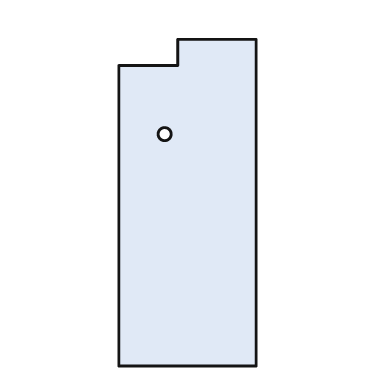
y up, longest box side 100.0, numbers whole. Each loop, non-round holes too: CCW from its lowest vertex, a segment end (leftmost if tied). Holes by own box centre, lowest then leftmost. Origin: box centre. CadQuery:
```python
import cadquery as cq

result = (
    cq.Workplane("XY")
    .moveTo(-21.0, -50.0)
    .lineTo(21.0, -50.0)
    .lineTo(21.0, 50.0)
    .lineTo(-3.0, 50.0)
    .lineTo(-3.0, 42.0)
    .lineTo(-21.0, 42.0)
    .close()
    .moveTo(-7.0, 21.0)
    .circle(2.0)
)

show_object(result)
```